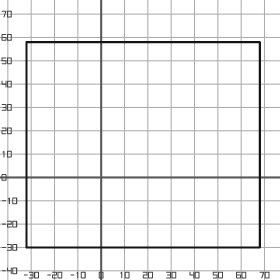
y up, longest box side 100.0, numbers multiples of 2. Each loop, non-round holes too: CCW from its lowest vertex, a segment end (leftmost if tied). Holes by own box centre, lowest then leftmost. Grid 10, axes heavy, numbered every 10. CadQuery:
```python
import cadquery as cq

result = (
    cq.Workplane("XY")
    .moveTo(-32.0, -30.0)
    .lineTo(68.0, -30.0)
    .lineTo(68.0, 58.0)
    .lineTo(-32.0, 58.0)
    .close()
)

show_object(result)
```